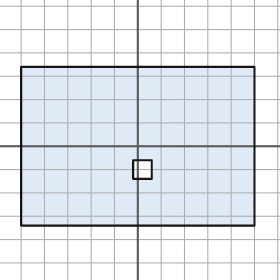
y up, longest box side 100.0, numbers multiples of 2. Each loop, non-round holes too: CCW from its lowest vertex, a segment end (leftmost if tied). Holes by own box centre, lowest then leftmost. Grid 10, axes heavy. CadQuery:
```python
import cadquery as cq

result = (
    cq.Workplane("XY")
    .moveTo(-50.0, -34.0)
    .lineTo(50.0, -34.0)
    .lineTo(50.0, 34.0)
    .lineTo(-50.0, 34.0)
    .close()
    .moveTo(-2.0, -14.0)
    .lineTo(6.0, -14.0)
    .lineTo(6.0, -6.0)
    .lineTo(-2.0, -6.0)
    .close()
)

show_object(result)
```